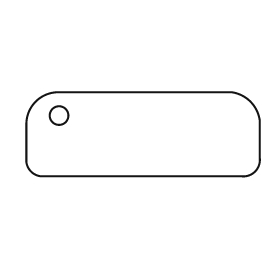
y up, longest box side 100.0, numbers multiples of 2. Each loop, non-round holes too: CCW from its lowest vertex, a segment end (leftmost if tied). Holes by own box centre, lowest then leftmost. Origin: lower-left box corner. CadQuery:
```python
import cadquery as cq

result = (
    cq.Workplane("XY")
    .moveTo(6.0, 0.0)
    .lineTo(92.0, 0.0)
    .threePointArc((98.0, 2.0), (100.0, 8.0))
    .lineTo(100.0, 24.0)
    .threePointArc((96.0, 32.0), (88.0, 36.0))
    .lineTo(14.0, 36.0)
    .threePointArc((4.0, 32.0), (0.0, 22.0))
    .lineTo(0.0, 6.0)
    .threePointArc((2.0, 2.0), (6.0, 0.0))
    .close()
    .moveTo(14.0, 26.0)
    .circle(4.0)
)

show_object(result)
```